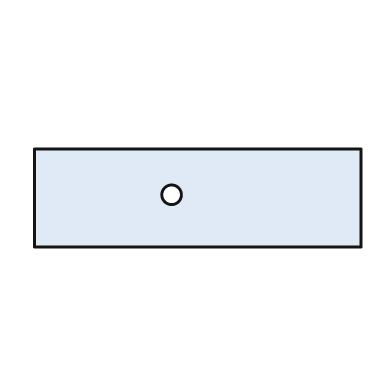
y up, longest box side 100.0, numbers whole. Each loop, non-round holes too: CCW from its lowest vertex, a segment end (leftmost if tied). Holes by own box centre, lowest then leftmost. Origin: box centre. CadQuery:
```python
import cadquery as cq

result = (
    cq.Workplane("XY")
    .moveTo(-50.0, -15.0)
    .lineTo(50.0, -15.0)
    .lineTo(50.0, 15.0)
    .lineTo(-50.0, 15.0)
    .close()
    .moveTo(-8.0, 1.0)
    .circle(3.0)
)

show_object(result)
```